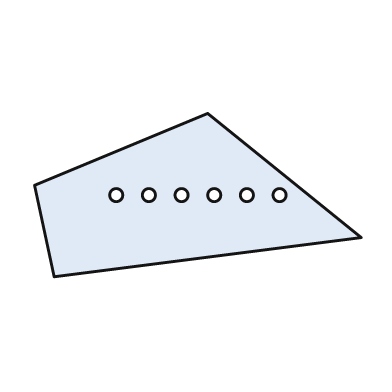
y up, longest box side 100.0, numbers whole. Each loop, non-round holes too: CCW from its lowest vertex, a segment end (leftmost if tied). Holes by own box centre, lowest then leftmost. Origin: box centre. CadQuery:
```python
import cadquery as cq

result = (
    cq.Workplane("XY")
    .moveTo(-44.0, -25.0)
    .lineTo(50.0, -13.0)
    .lineTo(3.0, 25.0)
    .lineTo(-50.0, 3.0)
    .close()
    .moveTo(-25.0, 0.0)
    .circle(2.0)
    .moveTo(-15.0, 0.0)
    .circle(2.0)
    .moveTo(-5.0, 0.0)
    .circle(2.0)
    .moveTo(5.0, 0.0)
    .circle(2.0)
    .moveTo(15.0, 0.0)
    .circle(2.0)
    .moveTo(25.0, 0.0)
    .circle(2.0)
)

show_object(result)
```